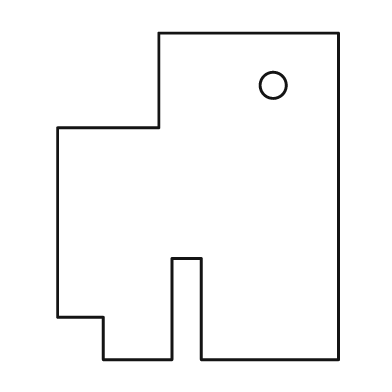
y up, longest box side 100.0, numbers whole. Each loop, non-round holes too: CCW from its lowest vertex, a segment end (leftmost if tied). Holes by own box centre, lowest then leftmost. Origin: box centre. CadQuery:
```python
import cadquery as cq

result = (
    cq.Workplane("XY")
    .moveTo(-29.0, -50.0)
    .lineTo(-8.0, -50.0)
    .lineTo(-8.0, -19.0)
    .lineTo(1.0, -19.0)
    .lineTo(1.0, -50.0)
    .lineTo(43.0, -50.0)
    .lineTo(43.0, 50.0)
    .lineTo(-12.0, 50.0)
    .lineTo(-12.0, 21.0)
    .lineTo(-43.0, 21.0)
    .lineTo(-43.0, -37.0)
    .lineTo(-29.0, -37.0)
    .close()
    .moveTo(23.0, 34.0)
    .circle(4.0)
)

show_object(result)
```